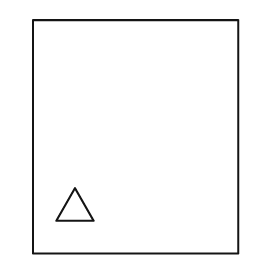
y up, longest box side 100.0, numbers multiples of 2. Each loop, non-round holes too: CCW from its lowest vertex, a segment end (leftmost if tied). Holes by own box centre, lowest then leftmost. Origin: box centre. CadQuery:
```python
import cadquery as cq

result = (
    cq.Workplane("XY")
    .moveTo(-44.0, -50.0)
    .lineTo(44.0, -50.0)
    .lineTo(44.0, 50.0)
    .lineTo(-44.0, 50.0)
    .close()
    .moveTo(-34.0, -36.0)
    .lineTo(-18.0, -36.0)
    .lineTo(-26.0, -22.0)
    .close()
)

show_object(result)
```